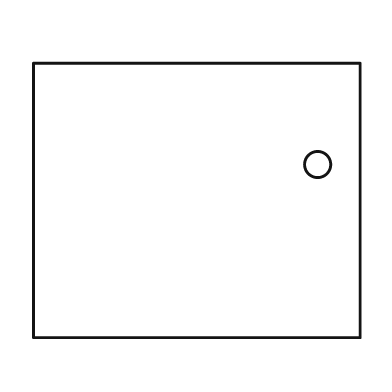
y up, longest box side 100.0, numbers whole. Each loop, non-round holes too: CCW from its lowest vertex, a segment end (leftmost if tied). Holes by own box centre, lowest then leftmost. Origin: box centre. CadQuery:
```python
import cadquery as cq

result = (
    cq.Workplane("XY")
    .moveTo(-50.0, -42.0)
    .lineTo(50.0, -42.0)
    .lineTo(50.0, 42.0)
    .lineTo(-50.0, 42.0)
    .close()
    .moveTo(37.0, 11.0)
    .circle(4.0)
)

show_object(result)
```